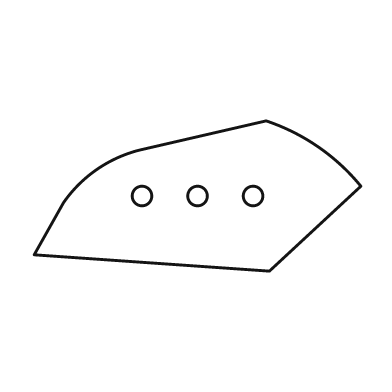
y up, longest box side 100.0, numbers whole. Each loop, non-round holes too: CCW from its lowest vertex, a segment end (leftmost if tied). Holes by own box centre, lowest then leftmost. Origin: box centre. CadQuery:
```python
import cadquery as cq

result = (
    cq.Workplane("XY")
    .moveTo(22.0, -23.0)
    .lineTo(50.0, 3.0)
    .threePointArc((37.0, 15.0), (21.0, 23.0))
    .lineTo(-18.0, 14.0)
    .threePointArc((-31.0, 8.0), (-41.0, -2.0))
    .lineTo(-50.0, -18.0)
    .close()
    .moveTo(-17.0, 0.0)
    .circle(3.0)
    .moveTo(0.0, 0.0)
    .circle(3.0)
    .moveTo(17.0, 0.0)
    .circle(3.0)
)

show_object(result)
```